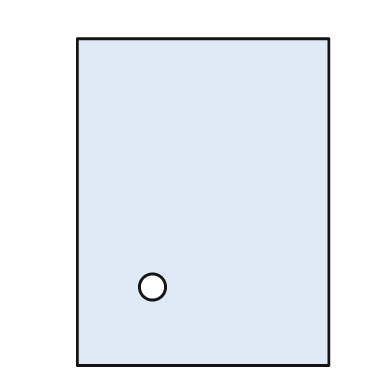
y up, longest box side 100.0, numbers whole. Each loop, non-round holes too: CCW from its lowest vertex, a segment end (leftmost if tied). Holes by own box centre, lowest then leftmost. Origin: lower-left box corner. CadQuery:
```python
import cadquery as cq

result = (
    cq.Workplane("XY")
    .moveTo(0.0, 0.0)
    .lineTo(77.0, 0.0)
    .lineTo(77.0, 100.0)
    .lineTo(0.0, 100.0)
    .close()
    .moveTo(23.0, 24.0)
    .circle(4.0)
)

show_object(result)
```